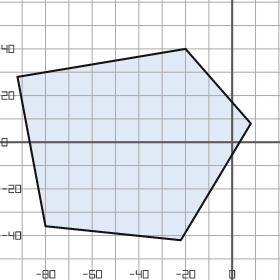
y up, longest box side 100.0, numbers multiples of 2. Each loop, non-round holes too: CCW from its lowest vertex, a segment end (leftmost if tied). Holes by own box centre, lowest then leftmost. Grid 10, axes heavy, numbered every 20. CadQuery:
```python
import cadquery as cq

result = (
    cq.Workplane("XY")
    .moveTo(-22.0, -42.0)
    .lineTo(8.0, 8.0)
    .lineTo(-20.0, 40.0)
    .lineTo(-92.0, 28.0)
    .lineTo(-80.0, -36.0)
    .close()
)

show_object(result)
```